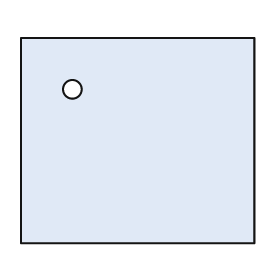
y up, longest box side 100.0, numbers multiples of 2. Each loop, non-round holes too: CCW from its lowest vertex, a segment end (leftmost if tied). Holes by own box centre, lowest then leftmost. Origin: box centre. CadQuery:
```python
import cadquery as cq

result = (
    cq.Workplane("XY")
    .moveTo(-50.0, -44.0)
    .lineTo(50.0, -44.0)
    .lineTo(50.0, 44.0)
    .lineTo(-50.0, 44.0)
    .close()
    .moveTo(-28.0, 22.0)
    .circle(4.0)
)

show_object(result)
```